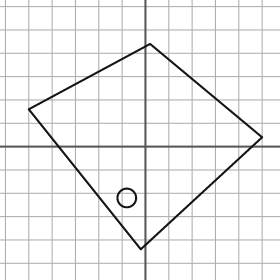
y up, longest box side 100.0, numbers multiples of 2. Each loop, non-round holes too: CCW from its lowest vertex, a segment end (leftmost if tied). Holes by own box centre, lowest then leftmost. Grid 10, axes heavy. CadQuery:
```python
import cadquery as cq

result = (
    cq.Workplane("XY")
    .moveTo(-2.0, -44.0)
    .lineTo(50.0, 4.0)
    .lineTo(2.0, 44.0)
    .lineTo(-50.0, 16.0)
    .close()
    .moveTo(-8.0, -22.0)
    .circle(4.0)
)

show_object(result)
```